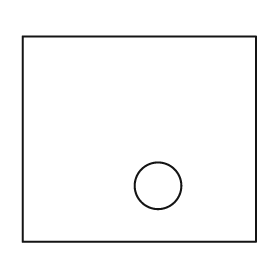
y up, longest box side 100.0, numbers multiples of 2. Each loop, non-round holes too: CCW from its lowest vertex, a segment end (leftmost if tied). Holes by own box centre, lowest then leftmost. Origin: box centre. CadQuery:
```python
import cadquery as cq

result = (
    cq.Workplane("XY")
    .moveTo(-50.0, -44.0)
    .lineTo(50.0, -44.0)
    .lineTo(50.0, 44.0)
    .lineTo(-50.0, 44.0)
    .close()
    .moveTo(8.0, -20.0)
    .circle(10.0)
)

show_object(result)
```